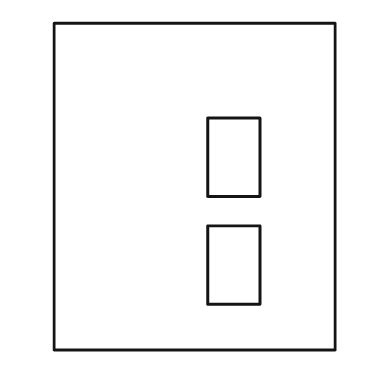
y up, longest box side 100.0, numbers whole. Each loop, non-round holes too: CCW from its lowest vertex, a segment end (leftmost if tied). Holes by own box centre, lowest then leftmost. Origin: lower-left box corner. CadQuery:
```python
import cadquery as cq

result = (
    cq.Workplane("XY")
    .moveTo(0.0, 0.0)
    .lineTo(86.0, 0.0)
    .lineTo(86.0, 100.0)
    .lineTo(0.0, 100.0)
    .close()
    .moveTo(47.0, 14.0)
    .lineTo(63.0, 14.0)
    .lineTo(63.0, 38.0)
    .lineTo(47.0, 38.0)
    .close()
    .moveTo(47.0, 47.0)
    .lineTo(63.0, 47.0)
    .lineTo(63.0, 71.0)
    .lineTo(47.0, 71.0)
    .close()
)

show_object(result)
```